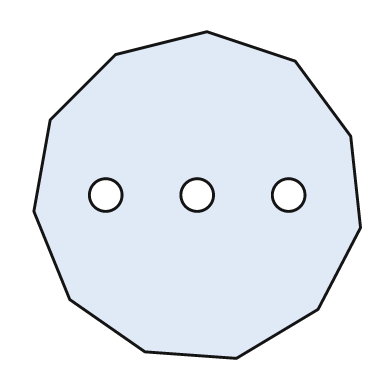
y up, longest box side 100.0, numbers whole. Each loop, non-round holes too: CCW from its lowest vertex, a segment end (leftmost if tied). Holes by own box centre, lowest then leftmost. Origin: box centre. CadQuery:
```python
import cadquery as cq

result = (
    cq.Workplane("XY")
    .moveTo(12.0, -50.0)
    .lineTo(37.0, -35.0)
    .lineTo(50.0, -10.0)
    .lineTo(47.0, 18.0)
    .lineTo(30.0, 41.0)
    .lineTo(3.0, 50.0)
    .lineTo(-25.0, 43.0)
    .lineTo(-45.0, 23.0)
    .lineTo(-50.0, -5.0)
    .lineTo(-39.0, -32.0)
    .lineTo(-16.0, -48.0)
    .close()
    .moveTo(-28.0, 0.0)
    .circle(5.0)
    .moveTo(0.0, 0.0)
    .circle(5.0)
    .moveTo(28.0, 0.0)
    .circle(5.0)
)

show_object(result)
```